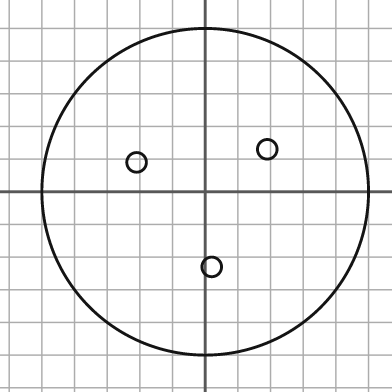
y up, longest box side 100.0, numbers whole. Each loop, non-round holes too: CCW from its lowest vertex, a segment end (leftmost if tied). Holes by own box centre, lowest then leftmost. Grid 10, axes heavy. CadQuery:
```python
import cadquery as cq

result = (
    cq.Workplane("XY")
    .moveTo(0.0, 0.0)
    .circle(50.0)
    .moveTo(2.0, -23.0)
    .circle(3.0)
    .moveTo(-21.0, 9.0)
    .circle(3.0)
    .moveTo(19.0, 13.0)
    .circle(3.0)
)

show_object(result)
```